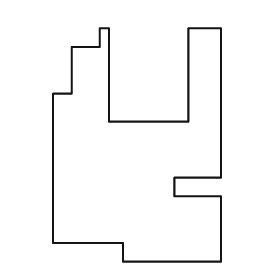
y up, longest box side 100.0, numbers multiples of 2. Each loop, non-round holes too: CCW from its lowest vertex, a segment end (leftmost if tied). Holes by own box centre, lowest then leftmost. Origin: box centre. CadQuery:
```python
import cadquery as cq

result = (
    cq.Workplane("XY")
    .moveTo(-6.0, -50.0)
    .lineTo(36.0, -50.0)
    .lineTo(36.0, -22.0)
    .lineTo(16.0, -22.0)
    .lineTo(16.0, -14.0)
    .lineTo(36.0, -14.0)
    .lineTo(36.0, 50.0)
    .lineTo(22.0, 50.0)
    .lineTo(22.0, 10.0)
    .lineTo(-12.0, 10.0)
    .lineTo(-12.0, 50.0)
    .lineTo(-16.0, 50.0)
    .lineTo(-16.0, 42.0)
    .lineTo(-28.0, 42.0)
    .lineTo(-28.0, 22.0)
    .lineTo(-36.0, 22.0)
    .lineTo(-36.0, -42.0)
    .lineTo(-6.0, -42.0)
    .close()
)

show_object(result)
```